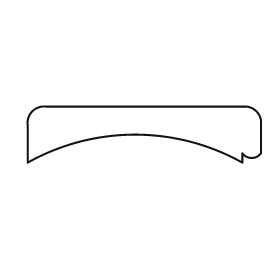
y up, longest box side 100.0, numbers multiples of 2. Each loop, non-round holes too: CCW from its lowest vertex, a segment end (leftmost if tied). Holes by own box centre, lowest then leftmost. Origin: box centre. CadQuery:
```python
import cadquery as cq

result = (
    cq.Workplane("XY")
    .moveTo(-50.0, -12.0)
    .threePointArc((-4.0, 0.0), (42.0, -12.0))
    .lineTo(42.0, -8.0)
    .threePointArc((46.0, -10.0), (50.0, -8.0))
    .lineTo(50.0, 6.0)
    .threePointArc((48.0, 10.0), (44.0, 12.0))
    .lineTo(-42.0, 12.0)
    .threePointArc((-48.0, 10.0), (-50.0, 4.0))
    .close()
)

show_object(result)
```